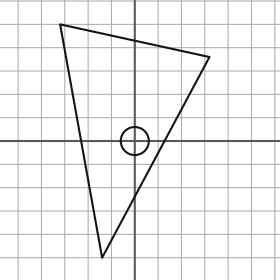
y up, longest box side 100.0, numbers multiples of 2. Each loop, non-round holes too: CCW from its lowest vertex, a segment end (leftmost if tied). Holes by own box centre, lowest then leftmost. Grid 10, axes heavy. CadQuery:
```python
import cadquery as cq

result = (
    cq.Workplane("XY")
    .moveTo(-14.0, -50.0)
    .lineTo(32.0, 36.0)
    .lineTo(-32.0, 50.0)
    .close()
    .moveTo(0.0, 0.0)
    .circle(6.0)
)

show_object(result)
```